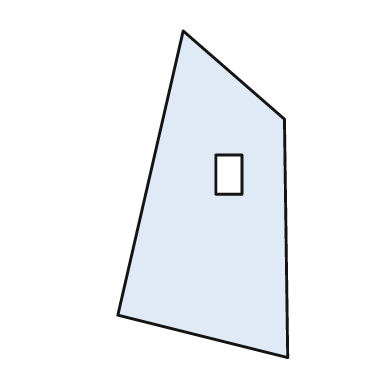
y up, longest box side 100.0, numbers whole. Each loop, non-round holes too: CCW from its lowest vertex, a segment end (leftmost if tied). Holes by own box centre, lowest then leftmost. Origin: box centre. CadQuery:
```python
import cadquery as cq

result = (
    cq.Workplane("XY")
    .moveTo(26.0, -50.0)
    .lineTo(25.0, 23.0)
    .lineTo(-6.0, 50.0)
    .lineTo(-26.0, -37.0)
    .close()
    .moveTo(4.0, 0.0)
    .lineTo(12.0, 0.0)
    .lineTo(12.0, 12.0)
    .lineTo(4.0, 12.0)
    .close()
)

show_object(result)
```